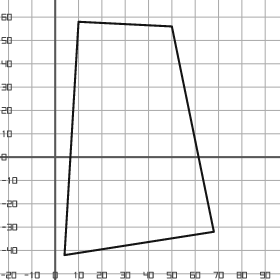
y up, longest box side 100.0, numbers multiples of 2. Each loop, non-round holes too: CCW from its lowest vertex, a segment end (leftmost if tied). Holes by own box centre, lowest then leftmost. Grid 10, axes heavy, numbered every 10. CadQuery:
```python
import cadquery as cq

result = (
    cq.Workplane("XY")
    .moveTo(4.0, -42.0)
    .lineTo(68.0, -32.0)
    .lineTo(50.0, 56.0)
    .lineTo(10.0, 58.0)
    .close()
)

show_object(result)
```